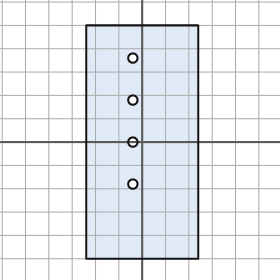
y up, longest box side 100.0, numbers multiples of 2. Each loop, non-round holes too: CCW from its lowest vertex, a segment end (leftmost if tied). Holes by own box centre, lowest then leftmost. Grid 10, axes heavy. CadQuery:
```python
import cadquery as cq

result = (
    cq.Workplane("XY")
    .moveTo(-24.0, -50.0)
    .lineTo(24.0, -50.0)
    .lineTo(24.0, 50.0)
    .lineTo(-24.0, 50.0)
    .close()
    .moveTo(-4.0, -18.0)
    .circle(2.0)
    .moveTo(-4.0, 0.0)
    .circle(2.0)
    .moveTo(-4.0, 18.0)
    .circle(2.0)
    .moveTo(-4.0, 36.0)
    .circle(2.0)
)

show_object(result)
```